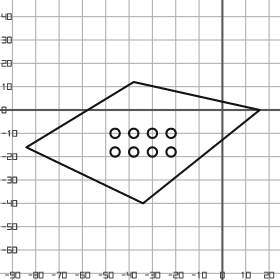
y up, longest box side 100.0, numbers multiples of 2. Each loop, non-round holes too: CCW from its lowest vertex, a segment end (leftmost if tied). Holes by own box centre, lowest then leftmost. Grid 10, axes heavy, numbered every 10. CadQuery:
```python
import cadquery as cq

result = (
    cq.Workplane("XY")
    .moveTo(-34.0, -40.0)
    .lineTo(16.0, 0.0)
    .lineTo(-38.0, 12.0)
    .lineTo(-84.0, -16.0)
    .close()
    .moveTo(-46.0, -18.0)
    .circle(2.0)
    .moveTo(-38.0, -18.0)
    .circle(2.0)
    .moveTo(-30.0, -18.0)
    .circle(2.0)
    .moveTo(-22.0, -18.0)
    .circle(2.0)
    .moveTo(-46.0, -10.0)
    .circle(2.0)
    .moveTo(-38.0, -10.0)
    .circle(2.0)
    .moveTo(-30.0, -10.0)
    .circle(2.0)
    .moveTo(-22.0, -10.0)
    .circle(2.0)
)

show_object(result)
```